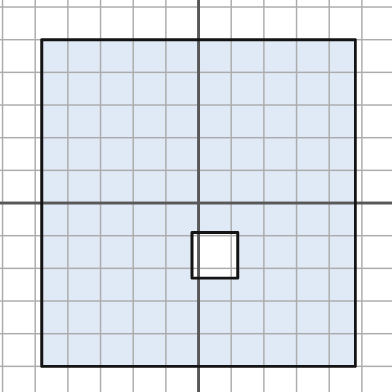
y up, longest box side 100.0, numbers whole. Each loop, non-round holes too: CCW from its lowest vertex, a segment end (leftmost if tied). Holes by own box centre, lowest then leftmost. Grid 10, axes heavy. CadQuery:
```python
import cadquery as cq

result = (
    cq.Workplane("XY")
    .moveTo(-48.0, -50.0)
    .lineTo(48.0, -50.0)
    .lineTo(48.0, 50.0)
    .lineTo(-48.0, 50.0)
    .close()
    .moveTo(-2.0, -23.0)
    .lineTo(12.0, -23.0)
    .lineTo(12.0, -9.0)
    .lineTo(-2.0, -9.0)
    .close()
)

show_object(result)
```